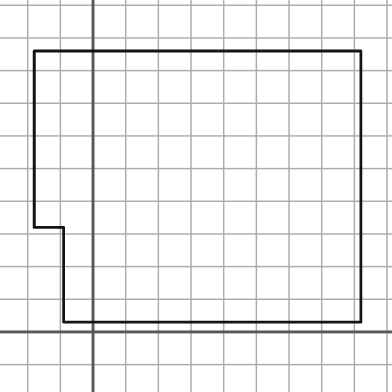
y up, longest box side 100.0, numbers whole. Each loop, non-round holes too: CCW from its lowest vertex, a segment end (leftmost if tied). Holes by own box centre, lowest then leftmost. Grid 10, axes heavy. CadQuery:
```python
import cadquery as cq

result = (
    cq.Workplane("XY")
    .moveTo(-9.0, 3.0)
    .lineTo(82.0, 3.0)
    .lineTo(82.0, 86.0)
    .lineTo(-18.0, 86.0)
    .lineTo(-18.0, 32.0)
    .lineTo(-9.0, 32.0)
    .close()
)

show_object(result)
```